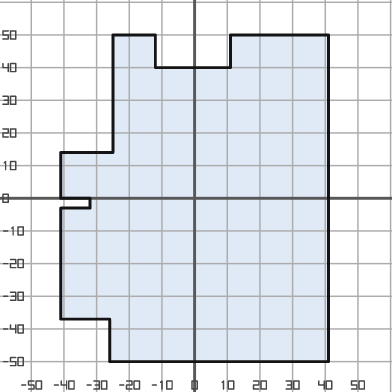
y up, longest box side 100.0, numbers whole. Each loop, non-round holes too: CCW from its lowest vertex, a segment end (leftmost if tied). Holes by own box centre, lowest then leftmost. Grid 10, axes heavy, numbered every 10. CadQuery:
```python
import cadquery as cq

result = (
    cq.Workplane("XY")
    .moveTo(-26.0, -50.0)
    .lineTo(41.0, -50.0)
    .lineTo(41.0, 50.0)
    .lineTo(11.0, 50.0)
    .lineTo(11.0, 40.0)
    .lineTo(-12.0, 40.0)
    .lineTo(-12.0, 50.0)
    .lineTo(-25.0, 50.0)
    .lineTo(-25.0, 14.0)
    .lineTo(-41.0, 14.0)
    .lineTo(-41.0, 0.0)
    .lineTo(-32.0, 0.0)
    .lineTo(-32.0, -3.0)
    .lineTo(-41.0, -3.0)
    .lineTo(-41.0, -37.0)
    .lineTo(-26.0, -37.0)
    .close()
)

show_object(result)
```